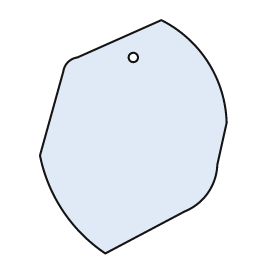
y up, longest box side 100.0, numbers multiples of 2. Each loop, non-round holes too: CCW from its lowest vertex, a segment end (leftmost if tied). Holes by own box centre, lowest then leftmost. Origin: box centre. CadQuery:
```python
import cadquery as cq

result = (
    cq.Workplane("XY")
    .moveTo(-12.0, -50.0)
    .lineTo(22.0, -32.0)
    .threePointArc((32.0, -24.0), (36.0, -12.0))
    .lineTo(40.0, 6.0)
    .threePointArc((32.0, 32.0), (12.0, 50.0))
    .lineTo(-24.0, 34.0)
    .threePointArc((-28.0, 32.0), (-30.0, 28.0))
    .lineTo(-40.0, -8.0)
    .threePointArc((-30.0, -32.0), (-12.0, -50.0))
    .close()
    .moveTo(0.0, 34.0)
    .circle(2.0)
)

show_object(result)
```